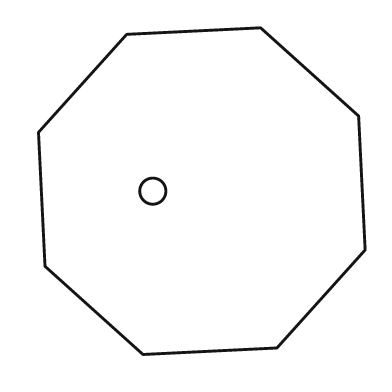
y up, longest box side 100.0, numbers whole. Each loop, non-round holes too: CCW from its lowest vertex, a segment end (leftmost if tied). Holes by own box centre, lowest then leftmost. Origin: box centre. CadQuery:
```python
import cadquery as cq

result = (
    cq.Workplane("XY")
    .moveTo(-18.0, -50.0)
    .lineTo(23.0, -48.0)
    .lineTo(50.0, -18.0)
    .lineTo(48.0, 23.0)
    .lineTo(18.0, 50.0)
    .lineTo(-23.0, 48.0)
    .lineTo(-50.0, 18.0)
    .lineTo(-48.0, -23.0)
    .close()
    .moveTo(-15.0, 0.0)
    .circle(4.0)
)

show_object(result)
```